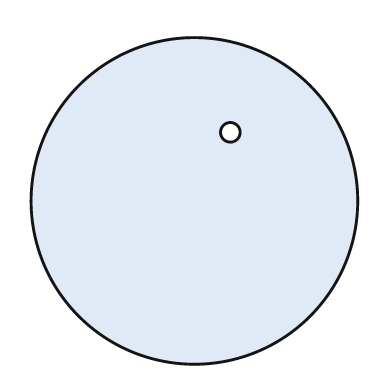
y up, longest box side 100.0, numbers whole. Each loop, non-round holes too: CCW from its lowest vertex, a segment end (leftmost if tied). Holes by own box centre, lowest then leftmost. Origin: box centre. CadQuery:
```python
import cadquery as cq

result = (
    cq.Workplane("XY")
    .moveTo(0.0, 0.0)
    .circle(50.0)
    .moveTo(11.0, 21.0)
    .circle(3.0)
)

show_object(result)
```